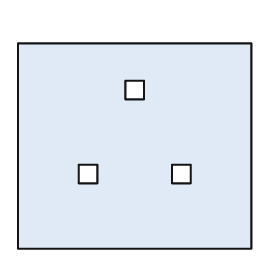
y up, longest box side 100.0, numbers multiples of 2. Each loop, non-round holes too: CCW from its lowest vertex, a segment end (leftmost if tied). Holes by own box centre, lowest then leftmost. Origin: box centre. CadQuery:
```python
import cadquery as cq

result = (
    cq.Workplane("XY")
    .moveTo(-50.0, -44.0)
    .lineTo(50.0, -44.0)
    .lineTo(50.0, 44.0)
    .lineTo(-50.0, 44.0)
    .close()
    .moveTo(-24.0, -16.0)
    .lineTo(-16.0, -16.0)
    .lineTo(-16.0, -8.0)
    .lineTo(-24.0, -8.0)
    .close()
    .moveTo(16.0, -16.0)
    .lineTo(24.0, -16.0)
    .lineTo(24.0, -8.0)
    .lineTo(16.0, -8.0)
    .close()
    .moveTo(-4.0, 20.0)
    .lineTo(4.0, 20.0)
    .lineTo(4.0, 28.0)
    .lineTo(-4.0, 28.0)
    .close()
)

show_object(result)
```